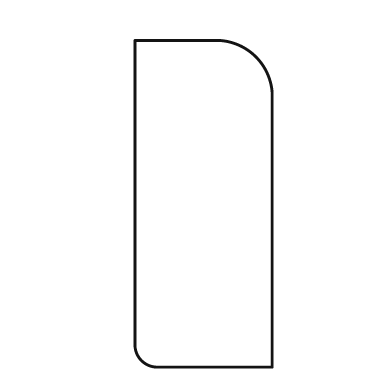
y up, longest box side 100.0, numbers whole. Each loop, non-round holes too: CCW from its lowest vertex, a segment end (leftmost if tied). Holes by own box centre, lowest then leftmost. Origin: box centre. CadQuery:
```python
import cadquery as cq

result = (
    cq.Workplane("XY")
    .moveTo(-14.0, -50.0)
    .lineTo(21.0, -50.0)
    .lineTo(21.0, 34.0)
    .threePointArc((16.0, 45.0), (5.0, 50.0))
    .lineTo(-21.0, 50.0)
    .lineTo(-21.0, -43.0)
    .threePointArc((-19.0, -48.0), (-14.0, -50.0))
    .close()
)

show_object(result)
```